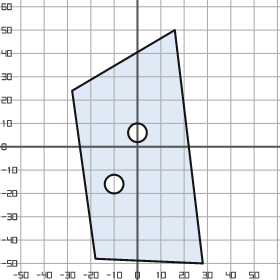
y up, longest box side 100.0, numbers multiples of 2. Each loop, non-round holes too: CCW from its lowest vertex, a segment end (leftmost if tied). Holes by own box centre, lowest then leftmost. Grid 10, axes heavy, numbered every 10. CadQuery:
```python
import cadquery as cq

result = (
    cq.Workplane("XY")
    .moveTo(28.0, -50.0)
    .lineTo(16.0, 50.0)
    .lineTo(-28.0, 24.0)
    .lineTo(-18.0, -48.0)
    .close()
    .moveTo(-10.0, -16.0)
    .circle(4.0)
    .moveTo(0.0, 6.0)
    .circle(4.0)
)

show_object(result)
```